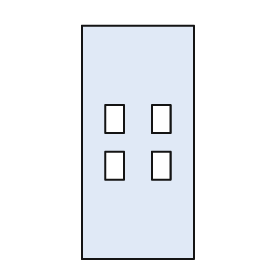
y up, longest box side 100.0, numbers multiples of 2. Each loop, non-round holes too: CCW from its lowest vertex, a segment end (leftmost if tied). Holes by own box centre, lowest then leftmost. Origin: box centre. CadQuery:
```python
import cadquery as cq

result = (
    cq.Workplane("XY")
    .moveTo(-24.0, -50.0)
    .lineTo(24.0, -50.0)
    .lineTo(24.0, 50.0)
    .lineTo(-24.0, 50.0)
    .close()
    .moveTo(-14.0, -16.0)
    .lineTo(-6.0, -16.0)
    .lineTo(-6.0, -4.0)
    .lineTo(-14.0, -4.0)
    .close()
    .moveTo(6.0, -16.0)
    .lineTo(14.0, -16.0)
    .lineTo(14.0, -4.0)
    .lineTo(6.0, -4.0)
    .close()
    .moveTo(-14.0, 4.0)
    .lineTo(-6.0, 4.0)
    .lineTo(-6.0, 16.0)
    .lineTo(-14.0, 16.0)
    .close()
    .moveTo(6.0, 4.0)
    .lineTo(14.0, 4.0)
    .lineTo(14.0, 16.0)
    .lineTo(6.0, 16.0)
    .close()
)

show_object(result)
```